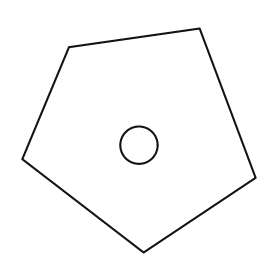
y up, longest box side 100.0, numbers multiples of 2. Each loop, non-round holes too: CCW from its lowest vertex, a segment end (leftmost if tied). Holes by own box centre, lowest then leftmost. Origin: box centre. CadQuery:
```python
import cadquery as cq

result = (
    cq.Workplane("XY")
    .moveTo(2.0, -48.0)
    .lineTo(50.0, -16.0)
    .lineTo(26.0, 48.0)
    .lineTo(-30.0, 40.0)
    .lineTo(-50.0, -8.0)
    .close()
    .moveTo(0.0, -2.0)
    .circle(8.0)
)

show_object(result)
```